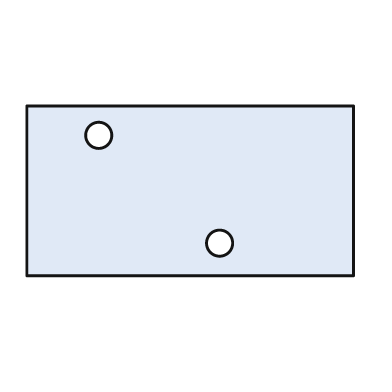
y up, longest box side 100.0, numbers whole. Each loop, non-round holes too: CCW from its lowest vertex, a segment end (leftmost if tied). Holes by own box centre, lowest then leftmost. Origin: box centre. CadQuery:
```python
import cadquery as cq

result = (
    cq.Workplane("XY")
    .moveTo(-50.0, -26.0)
    .lineTo(50.0, -26.0)
    .lineTo(50.0, 26.0)
    .lineTo(-50.0, 26.0)
    .close()
    .moveTo(9.0, -16.0)
    .circle(4.0)
    .moveTo(-28.0, 17.0)
    .circle(4.0)
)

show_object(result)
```